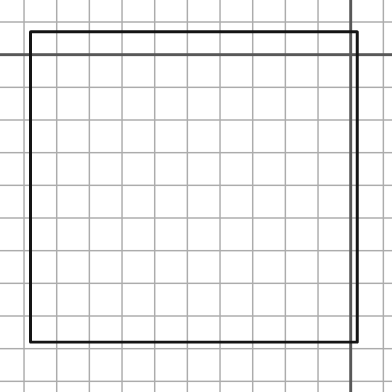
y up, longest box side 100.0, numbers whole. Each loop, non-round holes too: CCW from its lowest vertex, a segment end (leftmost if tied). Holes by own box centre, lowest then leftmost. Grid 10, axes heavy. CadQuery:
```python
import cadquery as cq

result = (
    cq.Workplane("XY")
    .moveTo(-98.0, -88.0)
    .lineTo(2.0, -88.0)
    .lineTo(2.0, 7.0)
    .lineTo(-98.0, 7.0)
    .close()
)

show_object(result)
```